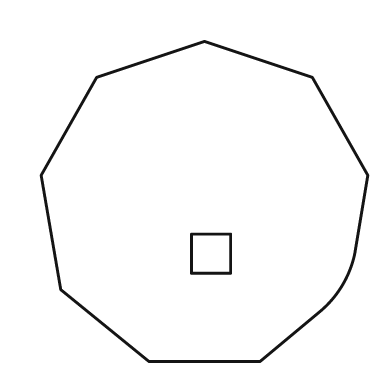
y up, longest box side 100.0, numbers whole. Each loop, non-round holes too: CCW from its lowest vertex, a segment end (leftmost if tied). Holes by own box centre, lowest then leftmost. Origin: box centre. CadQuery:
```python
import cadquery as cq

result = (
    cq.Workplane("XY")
    .moveTo(-17.0, -49.0)
    .lineTo(17.0, -49.0)
    .lineTo(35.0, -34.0)
    .threePointArc((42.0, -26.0), (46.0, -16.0))
    .lineTo(50.0, 8.0)
    .lineTo(33.0, 38.0)
    .lineTo(0.0, 49.0)
    .lineTo(-33.0, 38.0)
    .lineTo(-50.0, 8.0)
    .lineTo(-44.0, -27.0)
    .close()
    .moveTo(-4.0, -22.0)
    .lineTo(8.0, -22.0)
    .lineTo(8.0, -10.0)
    .lineTo(-4.0, -10.0)
    .close()
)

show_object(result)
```